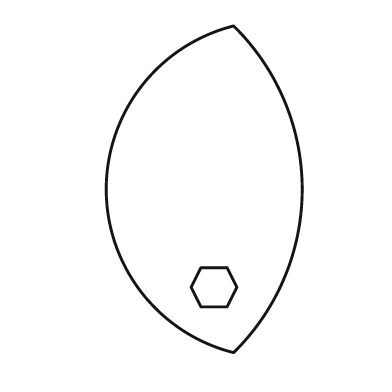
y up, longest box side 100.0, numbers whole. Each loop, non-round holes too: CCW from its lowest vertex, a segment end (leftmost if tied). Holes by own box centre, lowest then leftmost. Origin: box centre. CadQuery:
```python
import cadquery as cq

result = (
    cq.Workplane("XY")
    .moveTo(9.0, -50.0)
    .threePointArc((30.0, 0.0), (9.0, 50.0))
    .threePointArc((-30.0, 0.0), (9.0, -50.0))
    .close()
    .moveTo(-1.0, -36.0)
    .lineTo(7.0, -36.0)
    .lineTo(10.0, -30.0)
    .lineTo(7.0, -24.0)
    .lineTo(-1.0, -24.0)
    .lineTo(-4.0, -30.0)
    .close()
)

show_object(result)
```